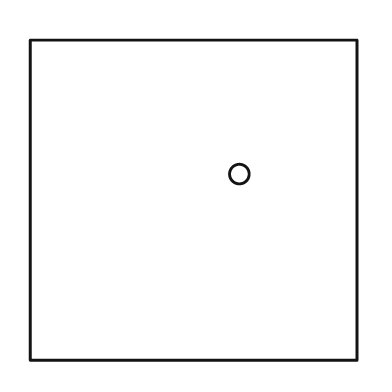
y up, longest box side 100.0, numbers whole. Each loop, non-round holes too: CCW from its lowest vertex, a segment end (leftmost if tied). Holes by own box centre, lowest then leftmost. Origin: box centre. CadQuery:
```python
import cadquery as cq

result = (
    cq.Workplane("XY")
    .moveTo(-50.0, -49.0)
    .lineTo(50.0, -49.0)
    .lineTo(50.0, 49.0)
    .lineTo(-50.0, 49.0)
    .close()
    .moveTo(14.0, 8.0)
    .circle(3.0)
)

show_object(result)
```